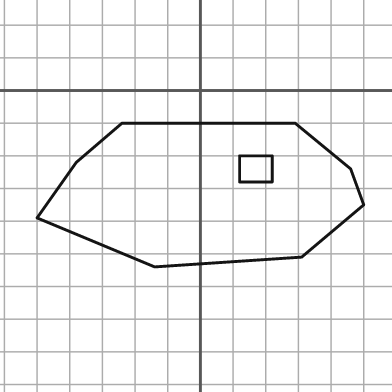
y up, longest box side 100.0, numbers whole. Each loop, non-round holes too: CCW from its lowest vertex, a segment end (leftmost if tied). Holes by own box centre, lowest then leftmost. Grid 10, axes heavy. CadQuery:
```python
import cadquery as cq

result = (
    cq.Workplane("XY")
    .moveTo(-14.0, -54.0)
    .lineTo(31.0, -51.0)
    .lineTo(50.0, -35.0)
    .lineTo(46.0, -24.0)
    .lineTo(29.0, -10.0)
    .lineTo(-24.0, -10.0)
    .lineTo(-38.0, -22.0)
    .lineTo(-50.0, -39.0)
    .close()
    .moveTo(12.0, -28.0)
    .lineTo(22.0, -28.0)
    .lineTo(22.0, -20.0)
    .lineTo(12.0, -20.0)
    .close()
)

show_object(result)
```